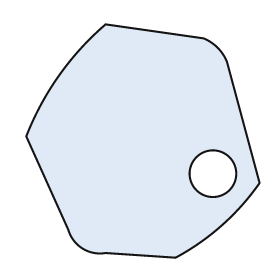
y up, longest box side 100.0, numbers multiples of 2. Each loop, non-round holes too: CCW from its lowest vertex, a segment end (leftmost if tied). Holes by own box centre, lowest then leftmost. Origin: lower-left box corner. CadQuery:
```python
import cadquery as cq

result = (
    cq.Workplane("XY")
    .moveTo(64.0, 0.0)
    .threePointArc((84.0, 14.0), (100.0, 32.0))
    .lineTo(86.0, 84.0)
    .threePointArc((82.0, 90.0), (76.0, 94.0))
    .lineTo(34.0, 100.0)
    .threePointArc((14.0, 78.0), (0.0, 52.0))
    .lineTo(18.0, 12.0)
    .threePointArc((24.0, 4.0), (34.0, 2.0))
    .close()
    .moveTo(80.0, 36.0)
    .circle(10.0)
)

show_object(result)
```